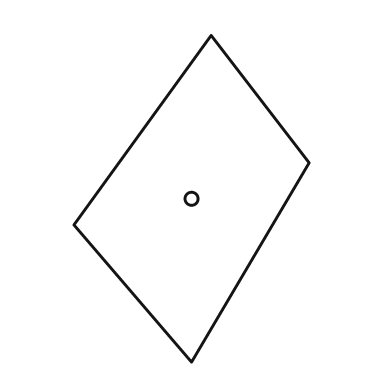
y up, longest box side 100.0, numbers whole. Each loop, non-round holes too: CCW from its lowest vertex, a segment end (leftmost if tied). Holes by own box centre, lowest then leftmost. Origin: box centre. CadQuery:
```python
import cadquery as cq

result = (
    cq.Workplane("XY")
    .moveTo(0.0, -50.0)
    .lineTo(36.0, 11.0)
    .lineTo(6.0, 50.0)
    .lineTo(-36.0, -8.0)
    .close()
    .moveTo(0.0, 0.0)
    .circle(2.0)
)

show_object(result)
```